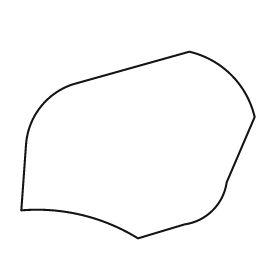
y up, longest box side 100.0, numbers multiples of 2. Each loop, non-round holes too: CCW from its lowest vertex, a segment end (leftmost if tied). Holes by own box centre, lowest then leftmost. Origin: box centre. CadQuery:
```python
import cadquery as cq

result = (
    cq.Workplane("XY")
    .moveTo(0.0, -40.0)
    .lineTo(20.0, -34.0)
    .threePointArc((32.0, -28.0), (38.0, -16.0))
    .lineTo(50.0, 12.0)
    .threePointArc((40.0, 30.0), (22.0, 40.0))
    .lineTo(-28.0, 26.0)
    .threePointArc((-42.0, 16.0), (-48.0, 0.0))
    .lineTo(-50.0, -28.0)
    .threePointArc((-24.0, -30.0), (0.0, -40.0))
    .close()
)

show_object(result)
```